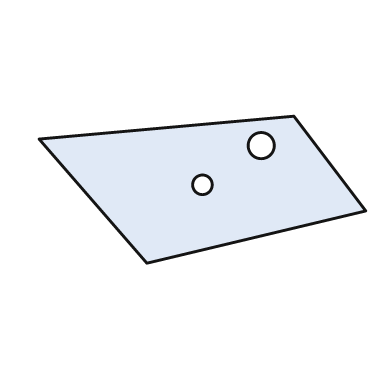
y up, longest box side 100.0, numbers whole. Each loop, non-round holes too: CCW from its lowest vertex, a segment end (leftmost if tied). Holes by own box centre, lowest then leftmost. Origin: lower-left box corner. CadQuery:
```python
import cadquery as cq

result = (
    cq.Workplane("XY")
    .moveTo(33.0, 0.0)
    .lineTo(100.0, 16.0)
    .lineTo(78.0, 45.0)
    .lineTo(0.0, 38.0)
    .close()
    .moveTo(50.0, 24.0)
    .circle(3.0)
    .moveTo(68.0, 36.0)
    .circle(4.0)
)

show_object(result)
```